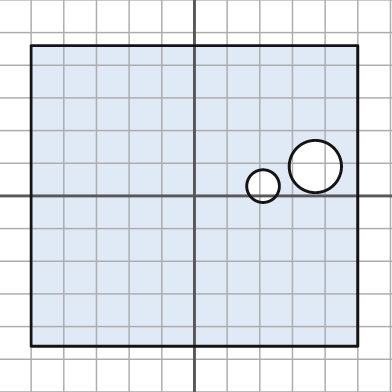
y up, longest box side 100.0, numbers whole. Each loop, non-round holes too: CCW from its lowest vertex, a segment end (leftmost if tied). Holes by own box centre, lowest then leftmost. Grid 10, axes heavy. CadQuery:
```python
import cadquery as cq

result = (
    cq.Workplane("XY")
    .moveTo(-50.0, -46.0)
    .lineTo(50.0, -46.0)
    .lineTo(50.0, 46.0)
    .lineTo(-50.0, 46.0)
    .close()
    .moveTo(21.0, 3.0)
    .circle(5.0)
    .moveTo(37.0, 9.0)
    .circle(8.0)
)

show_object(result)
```